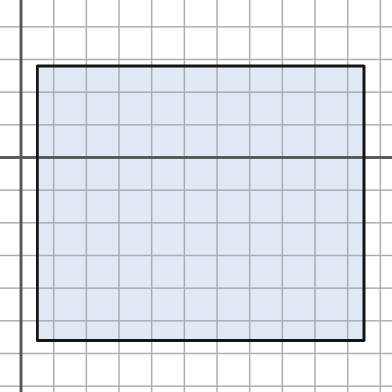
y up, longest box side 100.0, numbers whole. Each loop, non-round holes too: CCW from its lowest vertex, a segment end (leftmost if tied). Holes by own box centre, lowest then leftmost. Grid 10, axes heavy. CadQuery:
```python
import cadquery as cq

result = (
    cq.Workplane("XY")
    .moveTo(5.0, -56.0)
    .lineTo(105.0, -56.0)
    .lineTo(105.0, 28.0)
    .lineTo(5.0, 28.0)
    .close()
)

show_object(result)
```